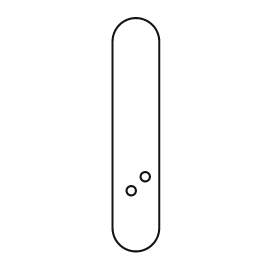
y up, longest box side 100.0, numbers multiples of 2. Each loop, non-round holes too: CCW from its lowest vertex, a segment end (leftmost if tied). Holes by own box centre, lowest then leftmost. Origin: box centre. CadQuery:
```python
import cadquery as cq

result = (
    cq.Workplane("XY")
    .moveTo(-10.0, -40.0)
    .threePointArc((0.0, -50.0), (10.0, -40.0))
    .lineTo(10.0, 40.0)
    .threePointArc((0.0, 50.0), (-10.0, 40.0))
    .close()
    .moveTo(-2.0, -24.0)
    .circle(2.0)
    .moveTo(4.0, -18.0)
    .circle(2.0)
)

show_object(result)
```